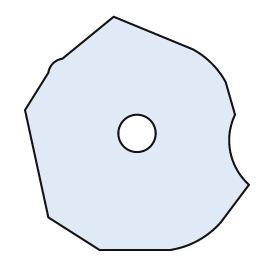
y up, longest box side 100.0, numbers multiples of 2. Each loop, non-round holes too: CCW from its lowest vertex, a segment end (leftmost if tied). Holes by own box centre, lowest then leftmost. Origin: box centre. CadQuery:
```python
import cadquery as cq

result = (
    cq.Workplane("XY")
    .moveTo(-16.0, -50.0)
    .lineTo(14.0, -50.0)
    .threePointArc((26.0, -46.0), (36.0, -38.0))
    .lineTo(48.0, -22.0)
    .threePointArc((40.0, -8.0), (42.0, 8.0))
    .lineTo(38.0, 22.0)
    .threePointArc((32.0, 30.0), (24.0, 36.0))
    .lineTo(-10.0, 50.0)
    .lineTo(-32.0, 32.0)
    .threePointArc((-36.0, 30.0), (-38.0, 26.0))
    .lineTo(-48.0, 10.0)
    .lineTo(-38.0, -36.0)
    .close()
    .moveTo(0.0, 0.0)
    .circle(8.0)
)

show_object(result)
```